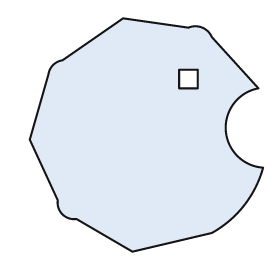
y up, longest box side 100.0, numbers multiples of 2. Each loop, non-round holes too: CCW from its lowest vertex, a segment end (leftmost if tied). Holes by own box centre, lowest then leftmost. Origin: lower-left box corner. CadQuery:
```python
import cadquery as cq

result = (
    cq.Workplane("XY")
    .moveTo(44.0, 0.0)
    .lineTo(78.0, 8.0)
    .threePointArc((92.0, 20.0), (100.0, 36.0))
    .threePointArc((84.0, 52.0), (98.0, 70.0))
    .lineTo(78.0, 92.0)
    .threePointArc((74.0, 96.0), (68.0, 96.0))
    .lineTo(40.0, 100.0)
    .lineTo(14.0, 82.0)
    .threePointArc((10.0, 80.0), (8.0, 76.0))
    .lineTo(0.0, 48.0)
    .lineTo(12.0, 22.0)
    .threePointArc((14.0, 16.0), (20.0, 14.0))
    .close()
    .moveTo(64.0, 70.0)
    .lineTo(72.0, 70.0)
    .lineTo(72.0, 78.0)
    .lineTo(64.0, 78.0)
    .close()
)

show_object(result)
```